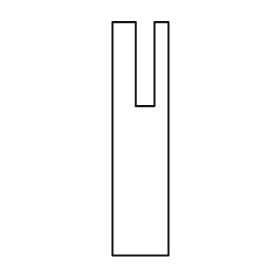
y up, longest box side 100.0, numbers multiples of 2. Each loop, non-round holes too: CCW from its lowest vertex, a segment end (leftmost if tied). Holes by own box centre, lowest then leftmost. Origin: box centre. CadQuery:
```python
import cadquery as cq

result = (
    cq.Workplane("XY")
    .moveTo(-12.0, -50.0)
    .lineTo(12.0, -50.0)
    .lineTo(12.0, 50.0)
    .lineTo(6.0, 50.0)
    .lineTo(6.0, 14.0)
    .lineTo(-2.0, 14.0)
    .lineTo(-2.0, 50.0)
    .lineTo(-12.0, 50.0)
    .close()
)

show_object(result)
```